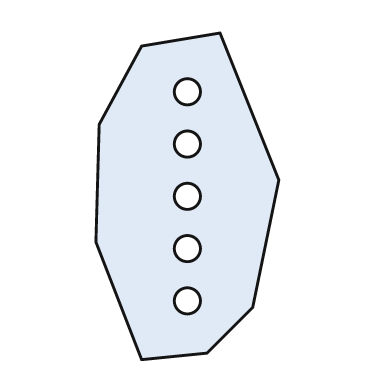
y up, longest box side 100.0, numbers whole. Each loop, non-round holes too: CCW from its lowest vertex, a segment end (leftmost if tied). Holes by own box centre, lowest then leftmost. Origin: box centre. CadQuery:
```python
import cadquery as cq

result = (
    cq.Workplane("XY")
    .moveTo(-14.0, -50.0)
    .lineTo(6.0, -48.0)
    .lineTo(20.0, -34.0)
    .lineTo(28.0, 5.0)
    .lineTo(10.0, 50.0)
    .lineTo(-14.0, 46.0)
    .lineTo(-27.0, 22.0)
    .lineTo(-28.0, -14.0)
    .close()
    .moveTo(0.0, -32.0)
    .circle(4.0)
    .moveTo(0.0, -16.0)
    .circle(4.0)
    .moveTo(0.0, 0.0)
    .circle(4.0)
    .moveTo(0.0, 16.0)
    .circle(4.0)
    .moveTo(0.0, 32.0)
    .circle(4.0)
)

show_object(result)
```